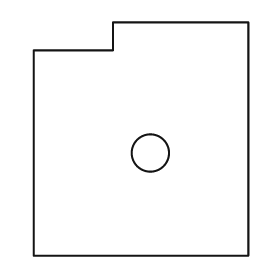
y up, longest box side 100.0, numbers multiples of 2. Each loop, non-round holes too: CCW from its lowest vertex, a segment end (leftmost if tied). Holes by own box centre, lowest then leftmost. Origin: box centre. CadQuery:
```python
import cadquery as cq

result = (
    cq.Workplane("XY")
    .moveTo(-46.0, -50.0)
    .lineTo(46.0, -50.0)
    .lineTo(46.0, 50.0)
    .lineTo(-12.0, 50.0)
    .lineTo(-12.0, 38.0)
    .lineTo(-46.0, 38.0)
    .close()
    .moveTo(4.0, -6.0)
    .circle(8.0)
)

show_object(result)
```